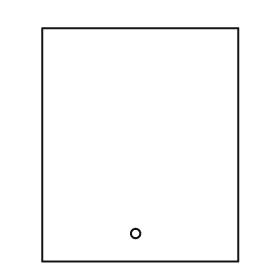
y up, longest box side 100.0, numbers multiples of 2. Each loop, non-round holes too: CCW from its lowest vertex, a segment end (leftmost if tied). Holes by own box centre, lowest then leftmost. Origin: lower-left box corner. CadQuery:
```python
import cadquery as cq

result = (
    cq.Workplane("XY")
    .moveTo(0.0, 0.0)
    .lineTo(84.0, 0.0)
    .lineTo(84.0, 100.0)
    .lineTo(0.0, 100.0)
    .close()
    .moveTo(40.0, 12.0)
    .circle(2.0)
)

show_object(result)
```